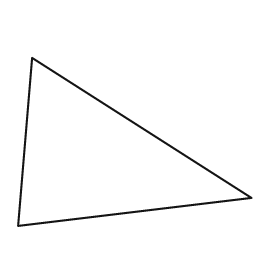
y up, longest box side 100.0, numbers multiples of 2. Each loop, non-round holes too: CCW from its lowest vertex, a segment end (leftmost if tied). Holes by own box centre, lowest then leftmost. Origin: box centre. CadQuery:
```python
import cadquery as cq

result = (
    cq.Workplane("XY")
    .moveTo(-50.0, -36.0)
    .lineTo(50.0, -24.0)
    .lineTo(-44.0, 36.0)
    .close()
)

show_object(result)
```